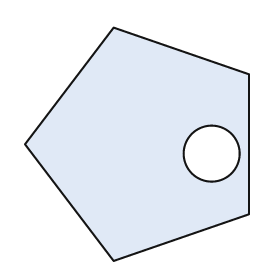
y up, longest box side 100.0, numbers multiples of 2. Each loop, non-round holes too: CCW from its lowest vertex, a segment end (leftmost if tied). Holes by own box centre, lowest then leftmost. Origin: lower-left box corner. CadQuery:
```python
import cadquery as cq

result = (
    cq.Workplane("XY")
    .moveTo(38.0, 0.0)
    .lineTo(96.0, 20.0)
    .lineTo(96.0, 80.0)
    .lineTo(38.0, 100.0)
    .lineTo(0.0, 50.0)
    .close()
    .moveTo(80.0, 46.0)
    .circle(12.0)
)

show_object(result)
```